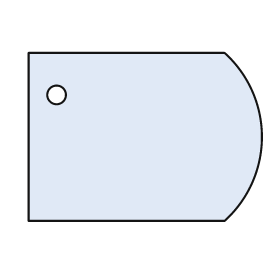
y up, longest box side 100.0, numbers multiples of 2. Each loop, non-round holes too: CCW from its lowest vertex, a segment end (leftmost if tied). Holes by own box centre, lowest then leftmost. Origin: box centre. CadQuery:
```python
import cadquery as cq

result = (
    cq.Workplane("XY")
    .moveTo(-50.0, -36.0)
    .lineTo(34.0, -36.0)
    .threePointArc((50.0, 0.0), (34.0, 36.0))
    .lineTo(-50.0, 36.0)
    .close()
    .moveTo(-38.0, 18.0)
    .circle(4.0)
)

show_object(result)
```